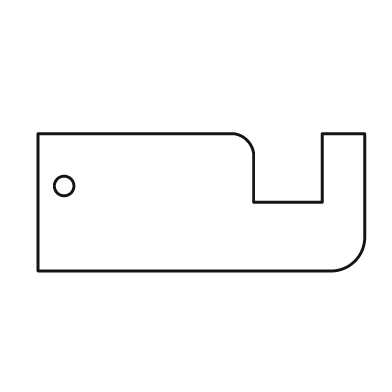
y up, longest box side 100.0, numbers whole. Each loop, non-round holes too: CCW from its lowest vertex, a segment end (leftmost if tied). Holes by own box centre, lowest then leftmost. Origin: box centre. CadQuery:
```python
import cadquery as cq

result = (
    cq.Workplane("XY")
    .moveTo(-50.0, -21.0)
    .lineTo(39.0, -21.0)
    .threePointArc((47.0, -18.0), (50.0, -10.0))
    .lineTo(50.0, 21.0)
    .lineTo(37.0, 21.0)
    .lineTo(37.0, 0.0)
    .lineTo(16.0, 0.0)
    .lineTo(16.0, 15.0)
    .threePointArc((14.0, 19.0), (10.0, 21.0))
    .lineTo(-50.0, 21.0)
    .close()
    .moveTo(-42.0, 5.0)
    .circle(3.0)
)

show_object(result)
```